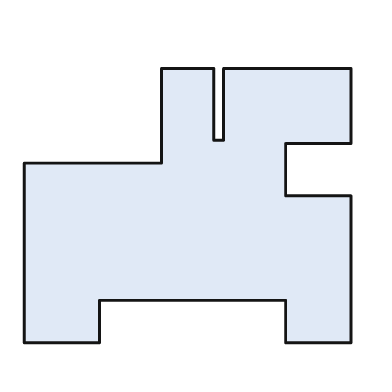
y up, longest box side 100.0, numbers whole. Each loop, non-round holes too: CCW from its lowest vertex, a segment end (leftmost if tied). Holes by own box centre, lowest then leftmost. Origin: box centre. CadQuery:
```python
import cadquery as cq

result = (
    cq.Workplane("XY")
    .moveTo(-50.0, -42.0)
    .lineTo(-27.0, -42.0)
    .lineTo(-27.0, -29.0)
    .lineTo(30.0, -29.0)
    .lineTo(30.0, -42.0)
    .lineTo(50.0, -42.0)
    .lineTo(50.0, 3.0)
    .lineTo(30.0, 3.0)
    .lineTo(30.0, 19.0)
    .lineTo(50.0, 19.0)
    .lineTo(50.0, 42.0)
    .lineTo(11.0, 42.0)
    .lineTo(11.0, 20.0)
    .lineTo(8.0, 20.0)
    .lineTo(8.0, 42.0)
    .lineTo(-8.0, 42.0)
    .lineTo(-8.0, 13.0)
    .lineTo(-50.0, 13.0)
    .close()
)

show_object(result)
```